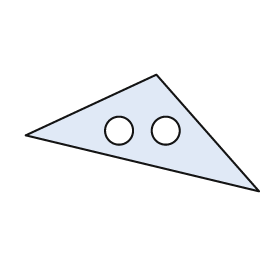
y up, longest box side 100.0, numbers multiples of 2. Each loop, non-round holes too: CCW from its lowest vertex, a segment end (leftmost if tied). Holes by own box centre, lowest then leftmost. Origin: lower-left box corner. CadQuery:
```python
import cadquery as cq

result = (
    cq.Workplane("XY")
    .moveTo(100.0, 0.0)
    .lineTo(56.0, 50.0)
    .lineTo(0.0, 24.0)
    .close()
    .moveTo(40.0, 26.0)
    .circle(6.0)
    .moveTo(60.0, 26.0)
    .circle(6.0)
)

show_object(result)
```